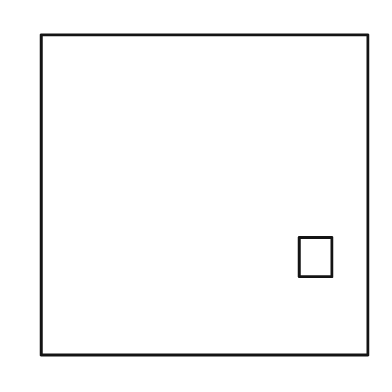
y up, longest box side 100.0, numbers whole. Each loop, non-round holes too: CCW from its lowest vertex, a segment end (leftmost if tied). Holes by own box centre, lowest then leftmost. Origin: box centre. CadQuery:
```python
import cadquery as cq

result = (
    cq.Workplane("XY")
    .moveTo(-50.0, -49.0)
    .lineTo(50.0, -49.0)
    .lineTo(50.0, 49.0)
    .lineTo(-50.0, 49.0)
    .close()
    .moveTo(29.0, -25.0)
    .lineTo(39.0, -25.0)
    .lineTo(39.0, -13.0)
    .lineTo(29.0, -13.0)
    .close()
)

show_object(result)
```